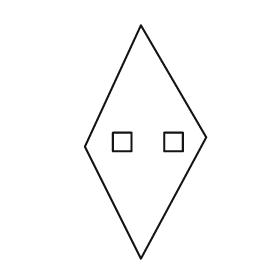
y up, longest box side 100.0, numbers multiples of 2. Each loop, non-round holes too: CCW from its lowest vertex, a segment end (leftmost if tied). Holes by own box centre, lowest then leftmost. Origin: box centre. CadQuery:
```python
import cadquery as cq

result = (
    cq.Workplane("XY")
    .moveTo(-2.0, -50.0)
    .lineTo(26.0, 2.0)
    .lineTo(-2.0, 50.0)
    .lineTo(-26.0, -2.0)
    .close()
    .moveTo(-14.0, -4.0)
    .lineTo(-6.0, -4.0)
    .lineTo(-6.0, 4.0)
    .lineTo(-14.0, 4.0)
    .close()
    .moveTo(8.0, -4.0)
    .lineTo(16.0, -4.0)
    .lineTo(16.0, 4.0)
    .lineTo(8.0, 4.0)
    .close()
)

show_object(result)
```